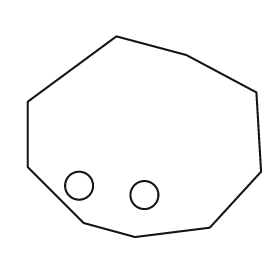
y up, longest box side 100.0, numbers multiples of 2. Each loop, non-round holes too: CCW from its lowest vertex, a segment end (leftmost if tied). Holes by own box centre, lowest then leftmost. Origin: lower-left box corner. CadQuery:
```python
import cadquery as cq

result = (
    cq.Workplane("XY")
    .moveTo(46.0, 0.0)
    .lineTo(78.0, 4.0)
    .lineTo(100.0, 28.0)
    .lineTo(98.0, 62.0)
    .lineTo(68.0, 78.0)
    .lineTo(38.0, 86.0)
    .lineTo(0.0, 58.0)
    .lineTo(0.0, 30.0)
    .lineTo(24.0, 6.0)
    .close()
    .moveTo(50.0, 18.0)
    .circle(6.0)
    .moveTo(22.0, 22.0)
    .circle(6.0)
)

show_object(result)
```